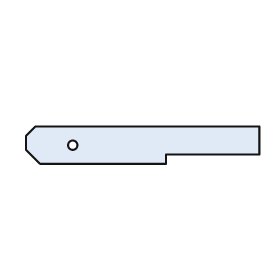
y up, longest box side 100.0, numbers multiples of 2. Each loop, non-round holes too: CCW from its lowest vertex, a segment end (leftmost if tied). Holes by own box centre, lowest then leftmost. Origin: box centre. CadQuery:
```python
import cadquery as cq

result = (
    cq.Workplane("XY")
    .moveTo(-44.0, -8.0)
    .lineTo(10.0, -8.0)
    .lineTo(10.0, -4.0)
    .lineTo(50.0, -4.0)
    .lineTo(50.0, 8.0)
    .lineTo(-46.0, 8.0)
    .lineTo(-50.0, 4.0)
    .lineTo(-50.0, -2.0)
    .close()
    .moveTo(-30.0, 0.0)
    .circle(2.0)
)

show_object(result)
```